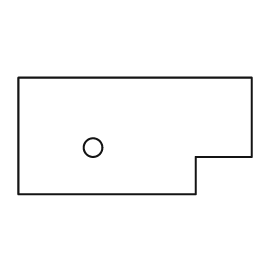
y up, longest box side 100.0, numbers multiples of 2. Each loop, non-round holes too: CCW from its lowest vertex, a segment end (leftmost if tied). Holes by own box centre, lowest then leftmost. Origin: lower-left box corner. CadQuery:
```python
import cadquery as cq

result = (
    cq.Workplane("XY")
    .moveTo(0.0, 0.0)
    .lineTo(76.0, 0.0)
    .lineTo(76.0, 16.0)
    .lineTo(100.0, 16.0)
    .lineTo(100.0, 50.0)
    .lineTo(0.0, 50.0)
    .close()
    .moveTo(32.0, 20.0)
    .circle(4.0)
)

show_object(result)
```